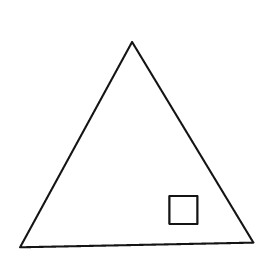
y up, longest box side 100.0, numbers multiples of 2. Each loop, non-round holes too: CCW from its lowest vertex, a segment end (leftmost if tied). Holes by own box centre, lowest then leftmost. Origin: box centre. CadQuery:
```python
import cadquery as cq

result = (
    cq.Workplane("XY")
    .moveTo(-50.0, -44.0)
    .lineTo(50.0, -42.0)
    .lineTo(-2.0, 44.0)
    .close()
    .moveTo(14.0, -34.0)
    .lineTo(26.0, -34.0)
    .lineTo(26.0, -22.0)
    .lineTo(14.0, -22.0)
    .close()
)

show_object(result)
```